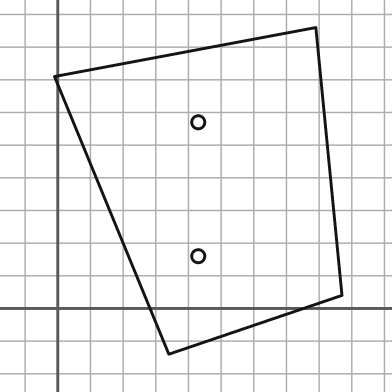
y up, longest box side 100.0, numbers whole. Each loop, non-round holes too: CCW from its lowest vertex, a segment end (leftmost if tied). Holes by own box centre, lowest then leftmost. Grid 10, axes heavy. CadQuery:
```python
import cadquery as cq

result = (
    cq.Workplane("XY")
    .moveTo(34.0, -14.0)
    .lineTo(87.0, 4.0)
    .lineTo(79.0, 86.0)
    .lineTo(-1.0, 71.0)
    .close()
    .moveTo(43.0, 16.0)
    .circle(2.0)
    .moveTo(43.0, 57.0)
    .circle(2.0)
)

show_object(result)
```